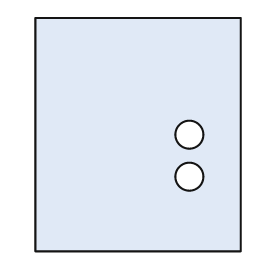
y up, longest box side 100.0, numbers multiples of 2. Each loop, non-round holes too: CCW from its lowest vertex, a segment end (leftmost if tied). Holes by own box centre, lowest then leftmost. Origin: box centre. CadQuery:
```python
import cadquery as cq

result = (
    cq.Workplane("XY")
    .moveTo(-44.0, -50.0)
    .lineTo(44.0, -50.0)
    .lineTo(44.0, 50.0)
    .lineTo(-44.0, 50.0)
    .close()
    .moveTo(22.0, -18.0)
    .circle(6.0)
    .moveTo(22.0, 0.0)
    .circle(6.0)
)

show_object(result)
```